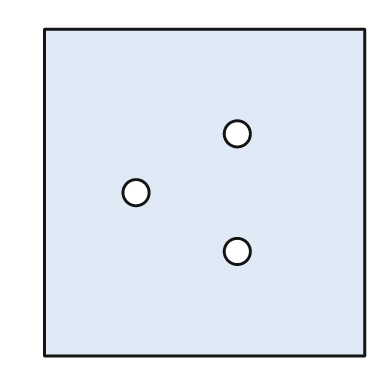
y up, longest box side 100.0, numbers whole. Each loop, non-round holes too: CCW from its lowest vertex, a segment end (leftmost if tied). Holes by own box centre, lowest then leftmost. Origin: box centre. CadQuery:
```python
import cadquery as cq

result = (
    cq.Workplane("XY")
    .moveTo(-49.0, -50.0)
    .lineTo(49.0, -50.0)
    .lineTo(49.0, 50.0)
    .lineTo(-49.0, 50.0)
    .close()
    .moveTo(10.0, -18.0)
    .circle(4.0)
    .moveTo(-21.0, 0.0)
    .circle(4.0)
    .moveTo(10.0, 18.0)
    .circle(4.0)
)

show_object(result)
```